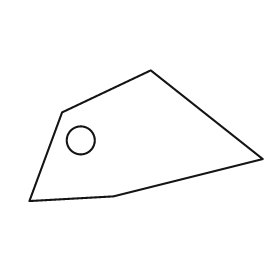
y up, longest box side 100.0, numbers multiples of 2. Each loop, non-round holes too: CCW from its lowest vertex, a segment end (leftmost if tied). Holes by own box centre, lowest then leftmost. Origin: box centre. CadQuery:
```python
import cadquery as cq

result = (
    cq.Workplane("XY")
    .moveTo(-50.0, -28.0)
    .lineTo(-14.0, -26.0)
    .lineTo(50.0, -10.0)
    .lineTo(2.0, 28.0)
    .lineTo(-36.0, 10.0)
    .close()
    .moveTo(-28.0, -2.0)
    .circle(6.0)
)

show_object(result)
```